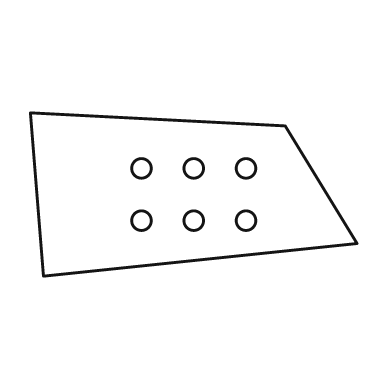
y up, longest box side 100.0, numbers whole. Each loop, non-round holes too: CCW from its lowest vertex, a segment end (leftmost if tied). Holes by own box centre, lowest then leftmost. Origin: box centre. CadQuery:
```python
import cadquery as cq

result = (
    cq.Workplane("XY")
    .moveTo(-46.0, -25.0)
    .lineTo(50.0, -15.0)
    .lineTo(28.0, 21.0)
    .lineTo(-50.0, 25.0)
    .close()
    .moveTo(-16.0, -8.0)
    .circle(3.0)
    .moveTo(0.0, -8.0)
    .circle(3.0)
    .moveTo(16.0, -8.0)
    .circle(3.0)
    .moveTo(-16.0, 8.0)
    .circle(3.0)
    .moveTo(0.0, 8.0)
    .circle(3.0)
    .moveTo(16.0, 8.0)
    .circle(3.0)
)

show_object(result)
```